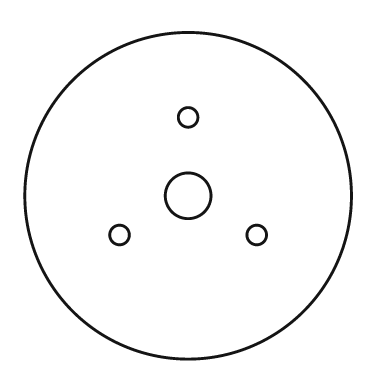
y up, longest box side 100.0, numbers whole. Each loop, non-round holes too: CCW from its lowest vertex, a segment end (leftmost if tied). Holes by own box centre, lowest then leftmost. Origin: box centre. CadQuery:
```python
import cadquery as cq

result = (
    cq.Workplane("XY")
    .moveTo(0.0, 0.0)
    .circle(50.0)
    .moveTo(-21.0, -12.0)
    .circle(3.0)
    .moveTo(21.0, -12.0)
    .circle(3.0)
    .moveTo(0.0, 0.0)
    .circle(7.0)
    .moveTo(0.0, 24.0)
    .circle(3.0)
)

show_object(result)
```